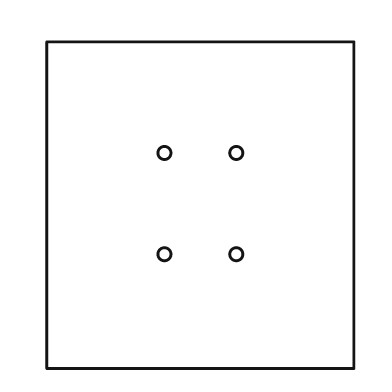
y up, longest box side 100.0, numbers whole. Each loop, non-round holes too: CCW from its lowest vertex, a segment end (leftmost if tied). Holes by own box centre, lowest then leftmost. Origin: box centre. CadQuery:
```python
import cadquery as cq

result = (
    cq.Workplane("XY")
    .moveTo(-47.0, -50.0)
    .lineTo(47.0, -50.0)
    .lineTo(47.0, 50.0)
    .lineTo(-47.0, 50.0)
    .close()
    .moveTo(-11.0, -15.0)
    .circle(2.0)
    .moveTo(11.0, -15.0)
    .circle(2.0)
    .moveTo(-11.0, 16.0)
    .circle(2.0)
    .moveTo(11.0, 16.0)
    .circle(2.0)
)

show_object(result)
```